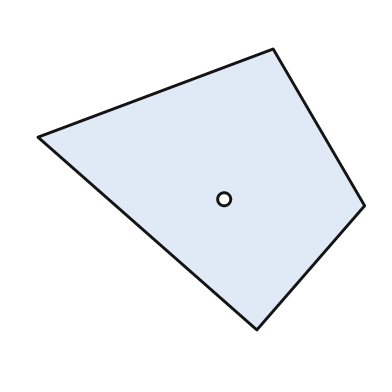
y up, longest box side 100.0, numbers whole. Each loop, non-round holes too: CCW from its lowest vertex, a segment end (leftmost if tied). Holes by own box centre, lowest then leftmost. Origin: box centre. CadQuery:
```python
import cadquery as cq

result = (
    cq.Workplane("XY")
    .moveTo(17.0, -43.0)
    .lineTo(50.0, -5.0)
    .lineTo(22.0, 43.0)
    .lineTo(-50.0, 16.0)
    .close()
    .moveTo(7.0, -3.0)
    .circle(2.0)
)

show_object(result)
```